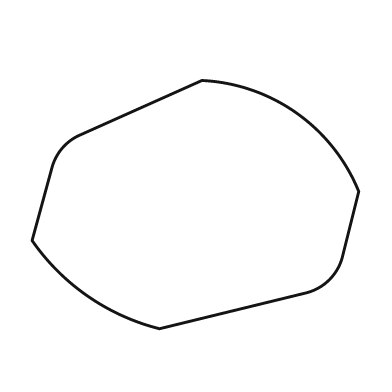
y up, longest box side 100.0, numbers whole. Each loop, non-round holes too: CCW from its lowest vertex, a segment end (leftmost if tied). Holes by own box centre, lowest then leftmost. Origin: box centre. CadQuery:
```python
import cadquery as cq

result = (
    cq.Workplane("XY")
    .moveTo(-11.0, -38.0)
    .lineTo(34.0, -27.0)
    .threePointArc((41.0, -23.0), (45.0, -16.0))
    .lineTo(50.0, 4.0)
    .threePointArc((31.0, 28.0), (2.0, 38.0))
    .lineTo(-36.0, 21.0)
    .threePointArc((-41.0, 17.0), (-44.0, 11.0))
    .lineTo(-50.0, -11.0)
    .threePointArc((-33.0, -28.0), (-11.0, -38.0))
    .close()
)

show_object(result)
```